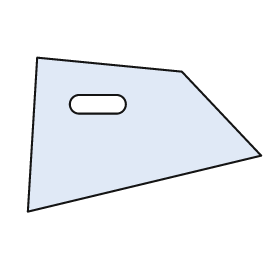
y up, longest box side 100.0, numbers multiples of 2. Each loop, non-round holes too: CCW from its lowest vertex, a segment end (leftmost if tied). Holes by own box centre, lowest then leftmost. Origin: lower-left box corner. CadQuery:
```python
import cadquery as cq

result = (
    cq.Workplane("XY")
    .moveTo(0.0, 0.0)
    .lineTo(100.0, 24.0)
    .lineTo(66.0, 60.0)
    .lineTo(4.0, 66.0)
    .close()
    .moveTo(22.0, 42.0)
    .lineTo(38.0, 42.0)
    .threePointArc((42.0, 46.0), (38.0, 50.0))
    .lineTo(22.0, 50.0)
    .threePointArc((18.0, 46.0), (22.0, 42.0))
    .close()
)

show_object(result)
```